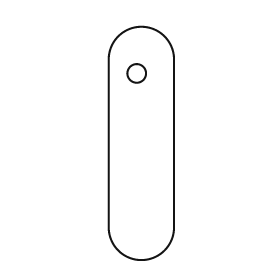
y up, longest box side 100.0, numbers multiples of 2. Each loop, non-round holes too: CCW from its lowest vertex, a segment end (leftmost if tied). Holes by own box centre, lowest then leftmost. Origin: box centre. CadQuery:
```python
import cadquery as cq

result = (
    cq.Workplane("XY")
    .moveTo(-14.0, -36.0)
    .threePointArc((0.0, -50.0), (14.0, -36.0))
    .lineTo(14.0, 36.0)
    .threePointArc((0.0, 50.0), (-14.0, 36.0))
    .close()
    .moveTo(-2.0, 30.0)
    .circle(4.0)
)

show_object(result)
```